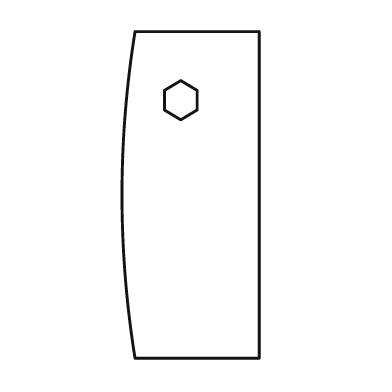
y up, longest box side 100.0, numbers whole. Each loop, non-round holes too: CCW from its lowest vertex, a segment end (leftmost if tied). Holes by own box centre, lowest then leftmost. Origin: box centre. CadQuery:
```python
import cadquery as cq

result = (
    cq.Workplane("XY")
    .moveTo(-17.0, -50.0)
    .lineTo(21.0, -50.0)
    .lineTo(21.0, 50.0)
    .lineTo(-17.0, 50.0)
    .threePointArc((-21.0, 0.0), (-17.0, -50.0))
    .close()
    .moveTo(-3.0, 23.0)
    .lineTo(2.0, 26.0)
    .lineTo(2.0, 32.0)
    .lineTo(-3.0, 35.0)
    .lineTo(-8.0, 32.0)
    .lineTo(-8.0, 26.0)
    .close()
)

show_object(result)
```